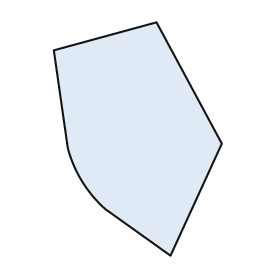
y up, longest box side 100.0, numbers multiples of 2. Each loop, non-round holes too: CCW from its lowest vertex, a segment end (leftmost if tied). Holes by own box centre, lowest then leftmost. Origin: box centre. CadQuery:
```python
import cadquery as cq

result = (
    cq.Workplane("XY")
    .moveTo(14.0, -50.0)
    .lineTo(36.0, -2.0)
    .lineTo(8.0, 50.0)
    .lineTo(-36.0, 38.0)
    .lineTo(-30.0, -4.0)
    .threePointArc((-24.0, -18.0), (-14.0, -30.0))
    .close()
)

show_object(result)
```